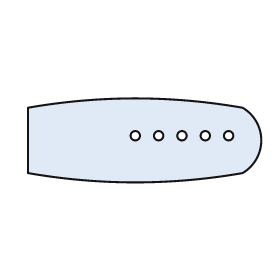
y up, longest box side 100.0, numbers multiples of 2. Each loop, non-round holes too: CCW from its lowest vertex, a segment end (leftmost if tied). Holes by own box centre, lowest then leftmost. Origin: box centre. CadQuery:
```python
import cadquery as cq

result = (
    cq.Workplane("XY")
    .moveTo(-50.0, -14.0)
    .threePointArc((-4.0, -18.0), (42.0, -14.0))
    .threePointArc((50.0, 0.0), (42.0, 14.0))
    .threePointArc((-4.0, 18.0), (-50.0, 14.0))
    .close()
    .moveTo(-4.0, 2.0)
    .circle(2.0)
    .moveTo(6.0, 2.0)
    .circle(2.0)
    .moveTo(16.0, 2.0)
    .circle(2.0)
    .moveTo(26.0, 2.0)
    .circle(2.0)
    .moveTo(36.0, 2.0)
    .circle(2.0)
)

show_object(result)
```